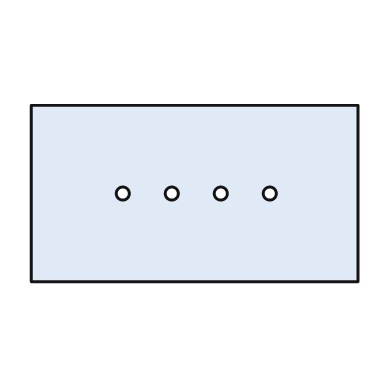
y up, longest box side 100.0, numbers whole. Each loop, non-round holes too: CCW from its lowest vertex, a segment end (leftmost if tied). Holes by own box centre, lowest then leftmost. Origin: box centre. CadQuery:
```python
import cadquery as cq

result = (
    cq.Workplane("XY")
    .moveTo(-50.0, -27.0)
    .lineTo(50.0, -27.0)
    .lineTo(50.0, 27.0)
    .lineTo(-50.0, 27.0)
    .close()
    .moveTo(-22.0, 0.0)
    .circle(2.0)
    .moveTo(-7.0, 0.0)
    .circle(2.0)
    .moveTo(8.0, 0.0)
    .circle(2.0)
    .moveTo(23.0, 0.0)
    .circle(2.0)
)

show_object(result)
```